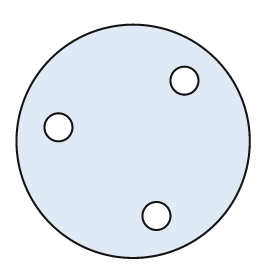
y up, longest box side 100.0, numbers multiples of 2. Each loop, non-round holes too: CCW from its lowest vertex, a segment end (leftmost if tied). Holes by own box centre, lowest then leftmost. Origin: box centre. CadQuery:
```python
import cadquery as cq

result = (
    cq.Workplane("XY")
    .moveTo(0.0, 0.0)
    .circle(50.0)
    .moveTo(10.0, -32.0)
    .circle(6.0)
    .moveTo(-32.0, 6.0)
    .circle(6.0)
    .moveTo(22.0, 26.0)
    .circle(6.0)
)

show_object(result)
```